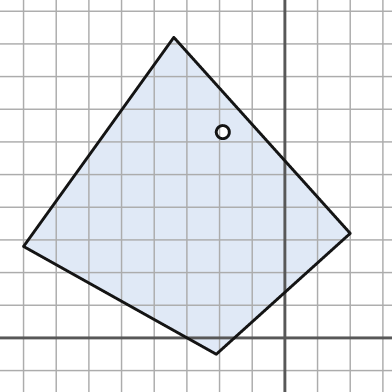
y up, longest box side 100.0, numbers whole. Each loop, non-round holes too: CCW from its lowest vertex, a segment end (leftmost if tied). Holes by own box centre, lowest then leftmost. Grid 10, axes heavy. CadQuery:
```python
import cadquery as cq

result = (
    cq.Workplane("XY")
    .moveTo(-21.0, -5.0)
    .lineTo(20.0, 32.0)
    .lineTo(-34.0, 92.0)
    .lineTo(-80.0, 28.0)
    .close()
    .moveTo(-19.0, 63.0)
    .circle(2.0)
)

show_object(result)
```